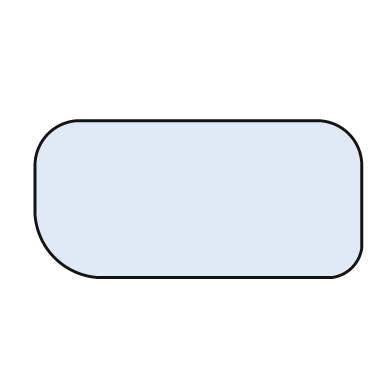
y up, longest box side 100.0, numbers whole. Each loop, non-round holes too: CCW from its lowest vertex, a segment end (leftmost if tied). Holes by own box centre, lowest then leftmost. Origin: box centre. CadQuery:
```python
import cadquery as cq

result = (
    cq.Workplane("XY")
    .moveTo(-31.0, -24.0)
    .lineTo(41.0, -24.0)
    .threePointArc((47.0, -21.0), (50.0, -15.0))
    .lineTo(50.0, 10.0)
    .threePointArc((46.0, 20.0), (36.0, 24.0))
    .lineTo(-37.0, 24.0)
    .threePointArc((-46.0, 20.0), (-50.0, 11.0))
    .lineTo(-50.0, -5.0)
    .threePointArc((-44.0, -18.0), (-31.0, -24.0))
    .close()
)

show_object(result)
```